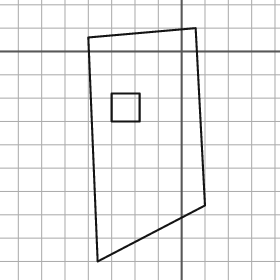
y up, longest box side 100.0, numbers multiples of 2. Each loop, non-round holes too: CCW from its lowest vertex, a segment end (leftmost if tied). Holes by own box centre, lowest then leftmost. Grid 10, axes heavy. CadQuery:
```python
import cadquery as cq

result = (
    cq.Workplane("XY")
    .moveTo(-36.0, -90.0)
    .lineTo(10.0, -66.0)
    .lineTo(6.0, 10.0)
    .lineTo(-40.0, 6.0)
    .close()
    .moveTo(-30.0, -30.0)
    .lineTo(-18.0, -30.0)
    .lineTo(-18.0, -18.0)
    .lineTo(-30.0, -18.0)
    .close()
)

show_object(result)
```